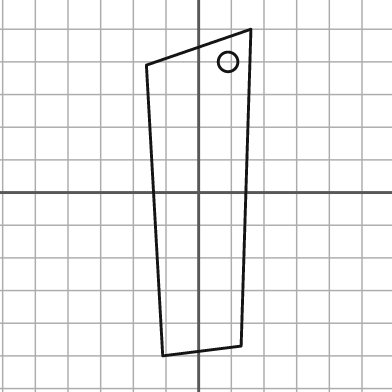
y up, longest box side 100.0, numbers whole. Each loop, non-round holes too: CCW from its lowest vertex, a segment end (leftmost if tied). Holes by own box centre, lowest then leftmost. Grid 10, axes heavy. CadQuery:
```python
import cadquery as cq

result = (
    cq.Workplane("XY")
    .moveTo(-11.0, -50.0)
    .lineTo(13.0, -47.0)
    .lineTo(16.0, 50.0)
    .lineTo(-16.0, 39.0)
    .close()
    .moveTo(9.0, 40.0)
    .circle(3.0)
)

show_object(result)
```